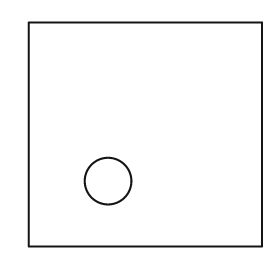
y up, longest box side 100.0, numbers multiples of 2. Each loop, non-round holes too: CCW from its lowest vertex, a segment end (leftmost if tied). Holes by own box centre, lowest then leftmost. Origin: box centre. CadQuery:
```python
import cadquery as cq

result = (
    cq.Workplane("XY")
    .moveTo(-50.0, -48.0)
    .lineTo(50.0, -48.0)
    .lineTo(50.0, 48.0)
    .lineTo(-50.0, 48.0)
    .close()
    .moveTo(-16.0, -20.0)
    .circle(10.0)
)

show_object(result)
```